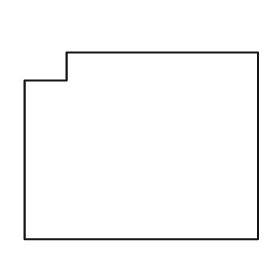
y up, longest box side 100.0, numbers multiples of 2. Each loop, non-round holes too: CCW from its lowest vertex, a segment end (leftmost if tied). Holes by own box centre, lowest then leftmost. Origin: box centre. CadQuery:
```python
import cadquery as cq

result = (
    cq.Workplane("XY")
    .moveTo(-50.0, -40.0)
    .lineTo(50.0, -40.0)
    .lineTo(50.0, 40.0)
    .lineTo(-32.0, 40.0)
    .lineTo(-32.0, 28.0)
    .lineTo(-50.0, 28.0)
    .close()
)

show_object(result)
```